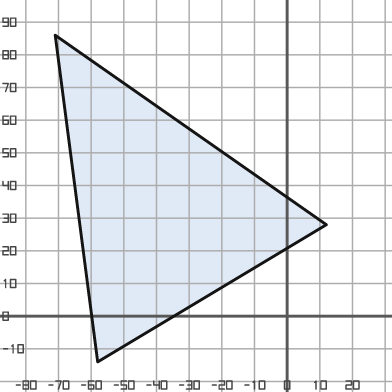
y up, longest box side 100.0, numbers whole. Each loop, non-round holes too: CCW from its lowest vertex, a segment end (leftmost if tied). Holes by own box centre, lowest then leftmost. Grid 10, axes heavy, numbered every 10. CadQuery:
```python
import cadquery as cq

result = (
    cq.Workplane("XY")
    .moveTo(-58.0, -14.0)
    .lineTo(12.0, 28.0)
    .lineTo(-71.0, 86.0)
    .close()
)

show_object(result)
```